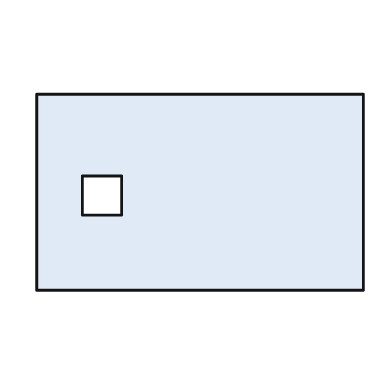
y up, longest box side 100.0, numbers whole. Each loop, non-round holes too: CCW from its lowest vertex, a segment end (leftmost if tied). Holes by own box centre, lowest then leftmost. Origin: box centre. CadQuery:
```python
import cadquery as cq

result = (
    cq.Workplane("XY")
    .moveTo(-50.0, -30.0)
    .lineTo(50.0, -30.0)
    .lineTo(50.0, 30.0)
    .lineTo(-50.0, 30.0)
    .close()
    .moveTo(-36.0, -7.0)
    .lineTo(-24.0, -7.0)
    .lineTo(-24.0, 5.0)
    .lineTo(-36.0, 5.0)
    .close()
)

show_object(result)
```